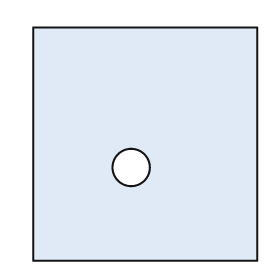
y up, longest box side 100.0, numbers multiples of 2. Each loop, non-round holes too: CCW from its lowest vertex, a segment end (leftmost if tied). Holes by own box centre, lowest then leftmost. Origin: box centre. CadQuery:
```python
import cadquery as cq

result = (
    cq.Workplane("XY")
    .moveTo(-48.0, -50.0)
    .lineTo(48.0, -50.0)
    .lineTo(48.0, 50.0)
    .lineTo(-48.0, 50.0)
    .close()
    .moveTo(-6.0, -10.0)
    .circle(8.0)
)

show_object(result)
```